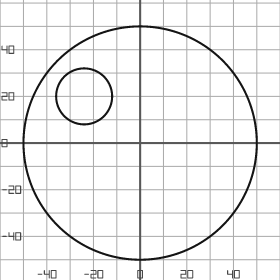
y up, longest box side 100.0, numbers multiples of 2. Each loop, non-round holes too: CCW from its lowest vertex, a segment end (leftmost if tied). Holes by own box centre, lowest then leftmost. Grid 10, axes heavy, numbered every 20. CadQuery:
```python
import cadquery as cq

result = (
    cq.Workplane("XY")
    .moveTo(0.0, 0.0)
    .circle(50.0)
    .moveTo(-24.0, 20.0)
    .circle(12.0)
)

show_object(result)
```